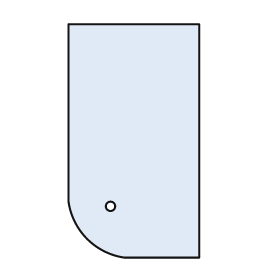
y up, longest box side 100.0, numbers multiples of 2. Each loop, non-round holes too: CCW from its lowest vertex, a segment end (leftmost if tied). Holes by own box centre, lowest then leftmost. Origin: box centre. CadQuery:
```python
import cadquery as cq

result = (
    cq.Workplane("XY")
    .moveTo(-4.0, -50.0)
    .lineTo(28.0, -50.0)
    .lineTo(28.0, 50.0)
    .lineTo(-28.0, 50.0)
    .lineTo(-28.0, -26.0)
    .threePointArc((-20.0, -42.0), (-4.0, -50.0))
    .close()
    .moveTo(-10.0, -28.0)
    .circle(2.0)
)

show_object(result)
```